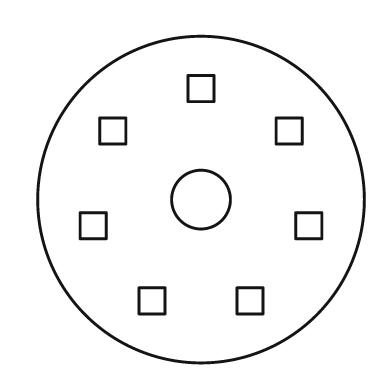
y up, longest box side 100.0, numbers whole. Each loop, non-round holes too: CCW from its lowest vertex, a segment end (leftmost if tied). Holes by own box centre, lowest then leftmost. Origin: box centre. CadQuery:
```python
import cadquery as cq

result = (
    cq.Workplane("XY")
    .moveTo(0.0, 0.0)
    .circle(50.0)
    .moveTo(-19.0, -35.0)
    .lineTo(-11.0, -35.0)
    .lineTo(-11.0, -27.0)
    .lineTo(-19.0, -27.0)
    .close()
    .moveTo(11.0, -35.0)
    .lineTo(19.0, -35.0)
    .lineTo(19.0, -27.0)
    .lineTo(11.0, -27.0)
    .close()
    .moveTo(-37.0, -12.0)
    .lineTo(-29.0, -12.0)
    .lineTo(-29.0, -4.0)
    .lineTo(-37.0, -4.0)
    .close()
    .moveTo(29.0, -12.0)
    .lineTo(37.0, -12.0)
    .lineTo(37.0, -4.0)
    .lineTo(29.0, -4.0)
    .close()
    .moveTo(0.0, 0.0)
    .circle(9.0)
    .moveTo(-31.0, 17.0)
    .lineTo(-23.0, 17.0)
    .lineTo(-23.0, 25.0)
    .lineTo(-31.0, 25.0)
    .close()
    .moveTo(23.0, 17.0)
    .lineTo(31.0, 17.0)
    .lineTo(31.0, 25.0)
    .lineTo(23.0, 25.0)
    .close()
    .moveTo(-4.0, 30.0)
    .lineTo(4.0, 30.0)
    .lineTo(4.0, 38.0)
    .lineTo(-4.0, 38.0)
    .close()
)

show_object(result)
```